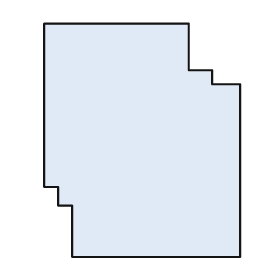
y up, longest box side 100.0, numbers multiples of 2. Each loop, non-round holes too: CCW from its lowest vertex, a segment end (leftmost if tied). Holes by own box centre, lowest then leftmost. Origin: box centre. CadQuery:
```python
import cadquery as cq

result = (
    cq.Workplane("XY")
    .moveTo(-30.0, -50.0)
    .lineTo(42.0, -50.0)
    .lineTo(42.0, 24.0)
    .lineTo(30.0, 24.0)
    .lineTo(30.0, 30.0)
    .lineTo(20.0, 30.0)
    .lineTo(20.0, 50.0)
    .lineTo(-42.0, 50.0)
    .lineTo(-42.0, -20.0)
    .lineTo(-36.0, -20.0)
    .lineTo(-36.0, -28.0)
    .lineTo(-30.0, -28.0)
    .close()
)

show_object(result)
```